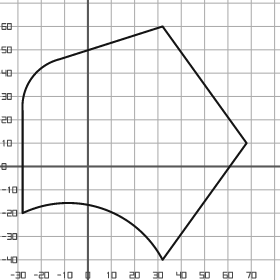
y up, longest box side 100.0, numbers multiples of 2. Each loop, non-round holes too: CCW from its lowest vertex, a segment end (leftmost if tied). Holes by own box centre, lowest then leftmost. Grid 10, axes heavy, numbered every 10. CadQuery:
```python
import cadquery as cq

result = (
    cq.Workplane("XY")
    .moveTo(32.0, -40.0)
    .lineTo(68.0, 10.0)
    .lineTo(32.0, 60.0)
    .lineTo(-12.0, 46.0)
    .threePointArc((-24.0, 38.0), (-28.0, 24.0))
    .lineTo(-28.0, -20.0)
    .threePointArc((6.0, -18.0), (32.0, -40.0))
    .close()
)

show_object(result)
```